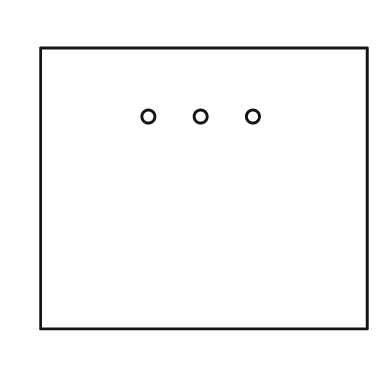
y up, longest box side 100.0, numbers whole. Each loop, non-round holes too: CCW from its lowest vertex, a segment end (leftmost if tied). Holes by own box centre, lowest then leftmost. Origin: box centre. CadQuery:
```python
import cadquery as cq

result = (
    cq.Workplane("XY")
    .moveTo(-50.0, -43.0)
    .lineTo(50.0, -43.0)
    .lineTo(50.0, 43.0)
    .lineTo(-50.0, 43.0)
    .close()
    .moveTo(-17.0, 22.0)
    .circle(2.0)
    .moveTo(-1.0, 22.0)
    .circle(2.0)
    .moveTo(15.0, 22.0)
    .circle(2.0)
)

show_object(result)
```